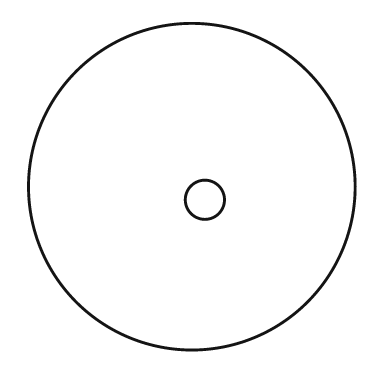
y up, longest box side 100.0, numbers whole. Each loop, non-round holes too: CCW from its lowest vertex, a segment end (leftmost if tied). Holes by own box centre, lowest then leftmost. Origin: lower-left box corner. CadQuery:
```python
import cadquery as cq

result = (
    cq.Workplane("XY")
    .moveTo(50.0, 50.0)
    .circle(50.0)
    .moveTo(54.0, 46.0)
    .circle(6.0)
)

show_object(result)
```